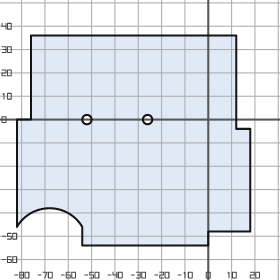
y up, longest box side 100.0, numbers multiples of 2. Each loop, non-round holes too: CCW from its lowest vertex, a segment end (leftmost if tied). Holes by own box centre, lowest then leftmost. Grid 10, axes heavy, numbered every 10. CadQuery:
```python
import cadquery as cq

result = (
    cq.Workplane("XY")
    .moveTo(-54.0, -54.0)
    .lineTo(0.0, -54.0)
    .lineTo(0.0, -48.0)
    .lineTo(18.0, -48.0)
    .lineTo(18.0, -4.0)
    .lineTo(12.0, -4.0)
    .lineTo(12.0, 36.0)
    .lineTo(-76.0, 36.0)
    .lineTo(-76.0, 0.0)
    .lineTo(-82.0, 0.0)
    .lineTo(-82.0, -46.0)
    .threePointArc((-68.0, -38.0), (-54.0, -46.0))
    .close()
    .moveTo(-52.0, 0.0)
    .circle(2.0)
    .moveTo(-26.0, 0.0)
    .circle(2.0)
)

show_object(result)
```